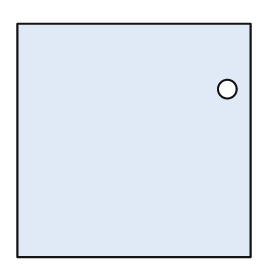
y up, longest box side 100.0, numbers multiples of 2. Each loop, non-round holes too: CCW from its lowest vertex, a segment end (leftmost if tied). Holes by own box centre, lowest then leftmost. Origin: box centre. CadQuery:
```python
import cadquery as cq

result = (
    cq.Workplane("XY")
    .moveTo(-50.0, -50.0)
    .lineTo(50.0, -50.0)
    .lineTo(50.0, 50.0)
    .lineTo(-50.0, 50.0)
    .close()
    .moveTo(40.0, 22.0)
    .circle(4.0)
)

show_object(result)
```